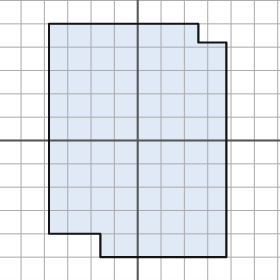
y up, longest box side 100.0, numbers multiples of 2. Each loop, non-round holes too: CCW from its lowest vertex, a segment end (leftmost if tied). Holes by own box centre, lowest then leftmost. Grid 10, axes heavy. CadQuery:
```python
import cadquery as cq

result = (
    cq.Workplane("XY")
    .moveTo(-16.0, -50.0)
    .lineTo(38.0, -50.0)
    .lineTo(38.0, 42.0)
    .lineTo(26.0, 42.0)
    .lineTo(26.0, 50.0)
    .lineTo(-38.0, 50.0)
    .lineTo(-38.0, -40.0)
    .lineTo(-16.0, -40.0)
    .close()
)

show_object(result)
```